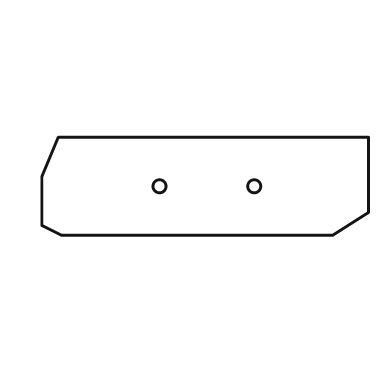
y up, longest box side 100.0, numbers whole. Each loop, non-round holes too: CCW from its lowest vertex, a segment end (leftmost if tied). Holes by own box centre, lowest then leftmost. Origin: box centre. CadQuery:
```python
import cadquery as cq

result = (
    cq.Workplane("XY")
    .moveTo(-44.0, -15.0)
    .lineTo(39.0, -15.0)
    .lineTo(50.0, -8.0)
    .lineTo(50.0, 15.0)
    .lineTo(-45.0, 15.0)
    .lineTo(-50.0, 3.0)
    .lineTo(-50.0, -12.0)
    .close()
    .moveTo(-14.0, 0.0)
    .circle(2.0)
    .moveTo(15.0, 0.0)
    .circle(2.0)
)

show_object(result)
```